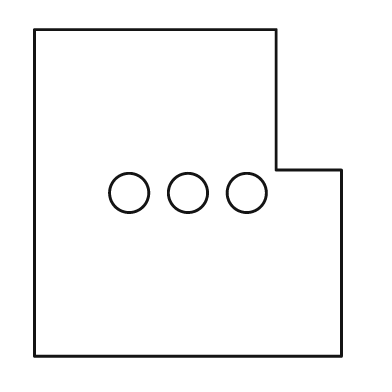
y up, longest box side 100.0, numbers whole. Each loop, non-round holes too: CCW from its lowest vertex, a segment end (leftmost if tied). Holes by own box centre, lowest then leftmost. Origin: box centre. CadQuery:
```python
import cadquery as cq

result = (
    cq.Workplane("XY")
    .moveTo(-47.0, -50.0)
    .lineTo(47.0, -50.0)
    .lineTo(47.0, 7.0)
    .lineTo(27.0, 7.0)
    .lineTo(27.0, 50.0)
    .lineTo(-47.0, 50.0)
    .close()
    .moveTo(-18.0, 0.0)
    .circle(6.0)
    .moveTo(0.0, 0.0)
    .circle(6.0)
    .moveTo(18.0, 0.0)
    .circle(6.0)
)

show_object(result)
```